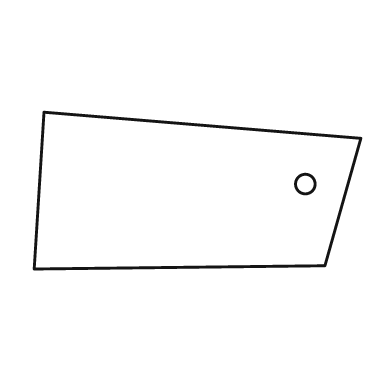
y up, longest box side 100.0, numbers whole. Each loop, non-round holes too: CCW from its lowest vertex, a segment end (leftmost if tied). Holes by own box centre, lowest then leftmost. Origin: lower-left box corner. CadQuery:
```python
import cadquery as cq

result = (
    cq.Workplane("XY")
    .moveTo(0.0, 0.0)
    .lineTo(89.0, 1.0)
    .lineTo(100.0, 40.0)
    .lineTo(3.0, 48.0)
    .close()
    .moveTo(83.0, 26.0)
    .circle(3.0)
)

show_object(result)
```